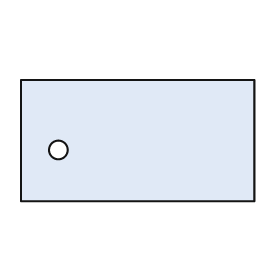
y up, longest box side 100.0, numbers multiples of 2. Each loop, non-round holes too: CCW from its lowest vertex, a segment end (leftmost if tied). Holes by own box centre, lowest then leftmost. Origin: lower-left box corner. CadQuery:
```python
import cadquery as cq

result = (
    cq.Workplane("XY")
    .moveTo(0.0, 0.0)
    .lineTo(100.0, 0.0)
    .lineTo(100.0, 52.0)
    .lineTo(0.0, 52.0)
    .close()
    .moveTo(16.0, 22.0)
    .circle(4.0)
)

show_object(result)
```